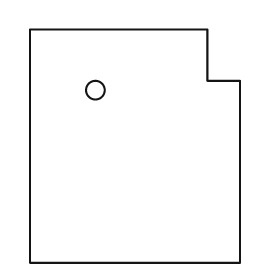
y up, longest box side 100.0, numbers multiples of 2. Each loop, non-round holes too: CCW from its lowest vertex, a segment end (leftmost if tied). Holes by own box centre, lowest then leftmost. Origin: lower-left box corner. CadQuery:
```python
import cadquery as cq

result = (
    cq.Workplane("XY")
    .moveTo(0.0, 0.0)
    .lineTo(90.0, 0.0)
    .lineTo(90.0, 78.0)
    .lineTo(76.0, 78.0)
    .lineTo(76.0, 100.0)
    .lineTo(0.0, 100.0)
    .close()
    .moveTo(28.0, 74.0)
    .circle(4.0)
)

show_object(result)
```